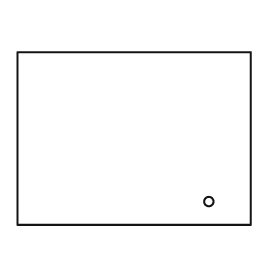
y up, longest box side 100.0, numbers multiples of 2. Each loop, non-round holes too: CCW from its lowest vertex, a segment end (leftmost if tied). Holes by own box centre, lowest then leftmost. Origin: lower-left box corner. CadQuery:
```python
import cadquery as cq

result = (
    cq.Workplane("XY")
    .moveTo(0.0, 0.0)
    .lineTo(100.0, 0.0)
    .lineTo(100.0, 74.0)
    .lineTo(0.0, 74.0)
    .close()
    .moveTo(82.0, 10.0)
    .circle(2.0)
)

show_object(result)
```